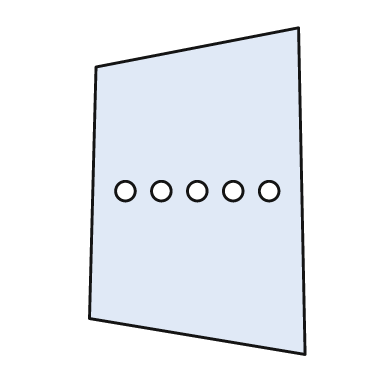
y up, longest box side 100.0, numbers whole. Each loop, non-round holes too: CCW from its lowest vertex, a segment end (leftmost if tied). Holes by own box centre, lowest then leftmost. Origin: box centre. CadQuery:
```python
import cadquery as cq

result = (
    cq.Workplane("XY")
    .moveTo(33.0, -50.0)
    .lineTo(31.0, 50.0)
    .lineTo(-31.0, 38.0)
    .lineTo(-33.0, -39.0)
    .close()
    .moveTo(-22.0, 0.0)
    .circle(3.0)
    .moveTo(-11.0, 0.0)
    .circle(3.0)
    .moveTo(0.0, 0.0)
    .circle(3.0)
    .moveTo(11.0, 0.0)
    .circle(3.0)
    .moveTo(22.0, 0.0)
    .circle(3.0)
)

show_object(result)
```